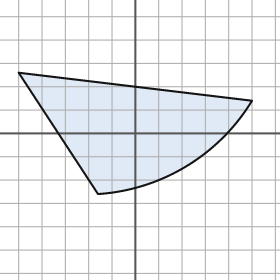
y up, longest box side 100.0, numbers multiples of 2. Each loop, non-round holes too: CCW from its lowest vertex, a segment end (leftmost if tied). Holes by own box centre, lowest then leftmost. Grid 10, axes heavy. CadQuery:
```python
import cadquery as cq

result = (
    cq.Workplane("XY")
    .moveTo(-16.0, -26.0)
    .threePointArc((22.0, -14.0), (50.0, 14.0))
    .lineTo(-50.0, 26.0)
    .close()
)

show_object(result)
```